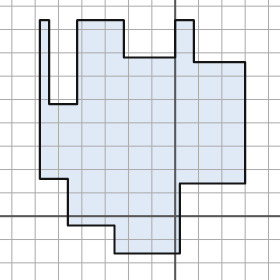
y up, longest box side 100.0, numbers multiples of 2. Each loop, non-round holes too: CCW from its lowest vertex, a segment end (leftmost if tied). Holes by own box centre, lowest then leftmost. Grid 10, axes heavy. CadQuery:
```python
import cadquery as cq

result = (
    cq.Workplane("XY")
    .moveTo(-26.0, -16.0)
    .lineTo(2.0, -16.0)
    .lineTo(2.0, 14.0)
    .lineTo(30.0, 14.0)
    .lineTo(30.0, 66.0)
    .lineTo(8.0, 66.0)
    .lineTo(8.0, 84.0)
    .lineTo(0.0, 84.0)
    .lineTo(0.0, 68.0)
    .lineTo(-22.0, 68.0)
    .lineTo(-22.0, 84.0)
    .lineTo(-42.0, 84.0)
    .lineTo(-42.0, 48.0)
    .lineTo(-54.0, 48.0)
    .lineTo(-54.0, 84.0)
    .lineTo(-58.0, 84.0)
    .lineTo(-58.0, 16.0)
    .lineTo(-46.0, 16.0)
    .lineTo(-46.0, -4.0)
    .lineTo(-26.0, -4.0)
    .close()
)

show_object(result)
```